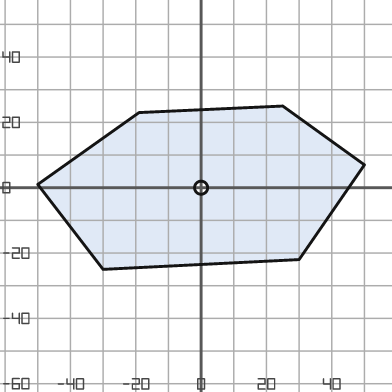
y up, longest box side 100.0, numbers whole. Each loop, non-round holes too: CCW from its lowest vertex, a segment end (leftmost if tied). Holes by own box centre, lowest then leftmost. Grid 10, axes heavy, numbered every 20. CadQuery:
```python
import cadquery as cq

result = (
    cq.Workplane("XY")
    .moveTo(-30.0, -25.0)
    .lineTo(30.0, -22.0)
    .lineTo(50.0, 7.0)
    .lineTo(25.0, 25.0)
    .lineTo(-19.0, 23.0)
    .lineTo(-50.0, 1.0)
    .close()
    .moveTo(0.0, 0.0)
    .circle(2.0)
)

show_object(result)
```